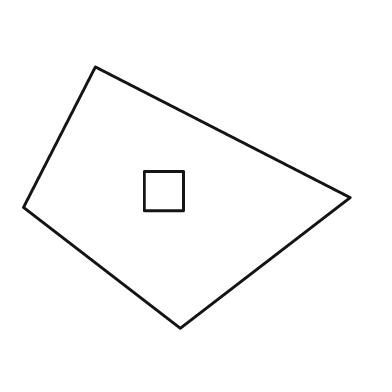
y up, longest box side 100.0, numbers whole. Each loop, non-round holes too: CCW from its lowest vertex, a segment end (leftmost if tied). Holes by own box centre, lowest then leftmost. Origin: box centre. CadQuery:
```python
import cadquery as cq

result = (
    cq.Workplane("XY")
    .moveTo(-2.0, -40.0)
    .lineTo(50.0, 0.0)
    .lineTo(-28.0, 40.0)
    .lineTo(-50.0, -3.0)
    .close()
    .moveTo(-13.0, -4.0)
    .lineTo(-1.0, -4.0)
    .lineTo(-1.0, 8.0)
    .lineTo(-13.0, 8.0)
    .close()
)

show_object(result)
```